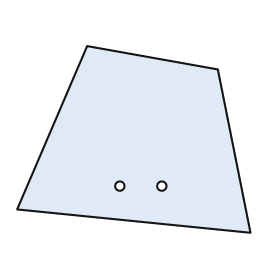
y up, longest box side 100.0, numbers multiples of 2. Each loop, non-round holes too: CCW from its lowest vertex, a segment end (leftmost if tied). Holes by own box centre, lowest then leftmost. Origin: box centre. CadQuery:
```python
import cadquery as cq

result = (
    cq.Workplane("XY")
    .moveTo(50.0, -40.0)
    .lineTo(36.0, 30.0)
    .lineTo(-20.0, 40.0)
    .lineTo(-50.0, -30.0)
    .close()
    .moveTo(-6.0, -20.0)
    .circle(2.0)
    .moveTo(12.0, -20.0)
    .circle(2.0)
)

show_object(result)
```